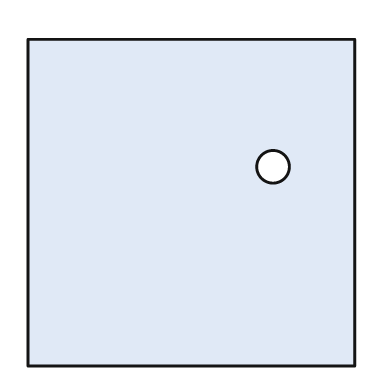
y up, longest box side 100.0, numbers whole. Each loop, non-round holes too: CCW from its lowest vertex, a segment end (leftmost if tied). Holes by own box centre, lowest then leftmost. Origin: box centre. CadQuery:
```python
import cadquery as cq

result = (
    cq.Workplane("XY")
    .moveTo(-50.0, -50.0)
    .lineTo(50.0, -50.0)
    .lineTo(50.0, 50.0)
    .lineTo(-50.0, 50.0)
    .close()
    .moveTo(25.0, 11.0)
    .circle(5.0)
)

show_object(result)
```